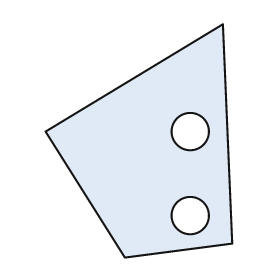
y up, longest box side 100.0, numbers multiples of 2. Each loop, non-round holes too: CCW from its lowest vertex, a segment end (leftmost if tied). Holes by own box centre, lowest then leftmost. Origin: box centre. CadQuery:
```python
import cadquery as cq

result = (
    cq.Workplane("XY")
    .moveTo(-6.0, -50.0)
    .lineTo(40.0, -44.0)
    .lineTo(36.0, 50.0)
    .lineTo(-40.0, 4.0)
    .close()
    .moveTo(22.0, -32.0)
    .circle(8.0)
    .moveTo(22.0, 4.0)
    .circle(8.0)
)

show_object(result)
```